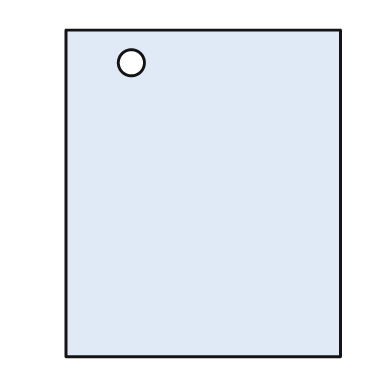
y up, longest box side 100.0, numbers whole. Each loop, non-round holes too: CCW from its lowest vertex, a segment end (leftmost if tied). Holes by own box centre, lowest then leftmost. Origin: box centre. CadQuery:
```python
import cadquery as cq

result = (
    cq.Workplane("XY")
    .moveTo(-42.0, -50.0)
    .lineTo(42.0, -50.0)
    .lineTo(42.0, 50.0)
    .lineTo(-42.0, 50.0)
    .close()
    .moveTo(-22.0, 40.0)
    .circle(4.0)
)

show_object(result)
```